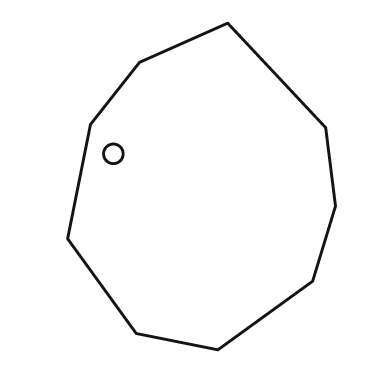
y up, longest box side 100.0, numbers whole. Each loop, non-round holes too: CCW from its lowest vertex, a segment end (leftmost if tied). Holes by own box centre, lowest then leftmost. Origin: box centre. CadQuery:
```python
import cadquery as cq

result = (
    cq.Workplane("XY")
    .moveTo(5.0, -50.0)
    .lineTo(34.0, -29.0)
    .lineTo(41.0, -6.0)
    .lineTo(38.0, 18.0)
    .lineTo(8.0, 50.0)
    .lineTo(-19.0, 38.0)
    .lineTo(-34.0, 19.0)
    .lineTo(-41.0, -16.0)
    .lineTo(-20.0, -45.0)
    .close()
    .moveTo(-27.0, 10.0)
    .circle(3.0)
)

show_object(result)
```